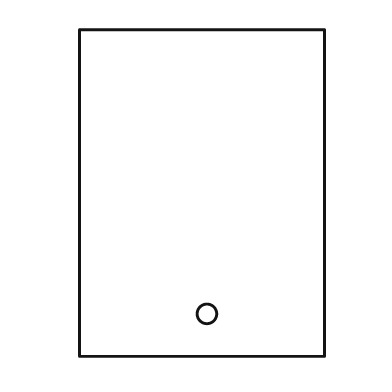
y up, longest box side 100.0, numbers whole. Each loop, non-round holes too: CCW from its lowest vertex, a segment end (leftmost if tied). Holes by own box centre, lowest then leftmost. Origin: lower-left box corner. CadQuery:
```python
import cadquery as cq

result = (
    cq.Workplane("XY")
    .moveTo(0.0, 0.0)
    .lineTo(75.0, 0.0)
    .lineTo(75.0, 100.0)
    .lineTo(0.0, 100.0)
    .close()
    .moveTo(39.0, 13.0)
    .circle(3.0)
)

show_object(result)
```